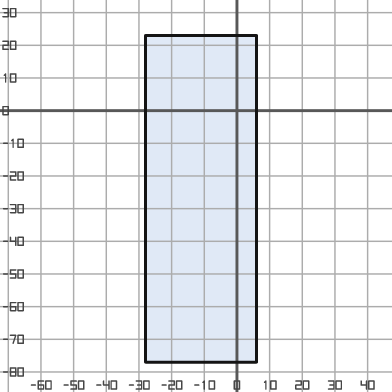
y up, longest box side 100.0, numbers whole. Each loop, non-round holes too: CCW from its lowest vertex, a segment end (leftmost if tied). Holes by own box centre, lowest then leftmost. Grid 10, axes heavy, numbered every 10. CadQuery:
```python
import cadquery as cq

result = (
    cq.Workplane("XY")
    .moveTo(-28.0, -77.0)
    .lineTo(6.0, -77.0)
    .lineTo(6.0, 23.0)
    .lineTo(-28.0, 23.0)
    .close()
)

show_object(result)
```